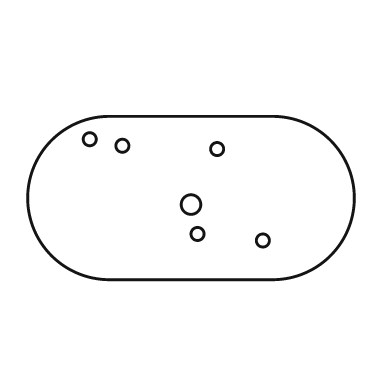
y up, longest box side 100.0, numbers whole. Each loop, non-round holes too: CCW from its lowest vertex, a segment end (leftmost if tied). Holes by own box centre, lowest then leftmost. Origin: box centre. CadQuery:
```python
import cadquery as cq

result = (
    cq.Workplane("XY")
    .moveTo(-25.0, -25.0)
    .lineTo(25.0, -25.0)
    .threePointArc((50.0, 0.0), (25.0, 25.0))
    .lineTo(-25.0, 25.0)
    .threePointArc((-50.0, 0.0), (-25.0, -25.0))
    .close()
    .moveTo(22.0, -13.0)
    .circle(2.0)
    .moveTo(2.0, -11.0)
    .circle(2.0)
    .moveTo(0.0, -2.0)
    .circle(3.0)
    .moveTo(8.0, 15.0)
    .circle(2.0)
    .moveTo(-21.0, 16.0)
    .circle(2.0)
    .moveTo(-31.0, 18.0)
    .circle(2.0)
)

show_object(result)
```